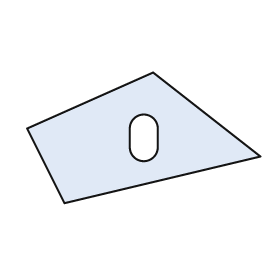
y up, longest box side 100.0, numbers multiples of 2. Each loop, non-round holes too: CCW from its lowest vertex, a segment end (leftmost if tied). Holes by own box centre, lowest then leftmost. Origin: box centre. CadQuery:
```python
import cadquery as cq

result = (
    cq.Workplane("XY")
    .moveTo(-34.0, -28.0)
    .lineTo(50.0, -8.0)
    .lineTo(4.0, 28.0)
    .lineTo(-50.0, 4.0)
    .close()
    .moveTo(-6.0, -4.0)
    .threePointArc((0.0, -10.0), (6.0, -4.0))
    .lineTo(6.0, 4.0)
    .threePointArc((0.0, 10.0), (-6.0, 4.0))
    .close()
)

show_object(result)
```